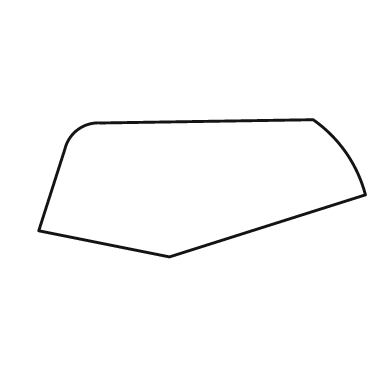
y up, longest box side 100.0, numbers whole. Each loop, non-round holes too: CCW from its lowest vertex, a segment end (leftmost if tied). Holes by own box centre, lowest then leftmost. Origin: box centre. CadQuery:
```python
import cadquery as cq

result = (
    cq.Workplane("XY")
    .moveTo(-10.0, -21.0)
    .lineTo(50.0, -2.0)
    .threePointArc((44.0, 11.0), (34.0, 21.0))
    .lineTo(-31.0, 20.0)
    .threePointArc((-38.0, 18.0), (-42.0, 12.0))
    .lineTo(-50.0, -13.0)
    .close()
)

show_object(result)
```